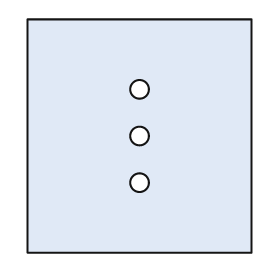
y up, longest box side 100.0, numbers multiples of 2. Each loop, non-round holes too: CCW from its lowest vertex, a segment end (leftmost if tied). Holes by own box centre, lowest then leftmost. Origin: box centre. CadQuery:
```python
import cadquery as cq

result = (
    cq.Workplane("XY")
    .moveTo(-48.0, -50.0)
    .lineTo(48.0, -50.0)
    .lineTo(48.0, 50.0)
    .lineTo(-48.0, 50.0)
    .close()
    .moveTo(0.0, -20.0)
    .circle(4.0)
    .moveTo(0.0, 0.0)
    .circle(4.0)
    .moveTo(0.0, 20.0)
    .circle(4.0)
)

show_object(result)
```